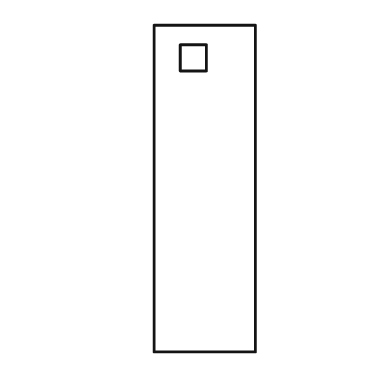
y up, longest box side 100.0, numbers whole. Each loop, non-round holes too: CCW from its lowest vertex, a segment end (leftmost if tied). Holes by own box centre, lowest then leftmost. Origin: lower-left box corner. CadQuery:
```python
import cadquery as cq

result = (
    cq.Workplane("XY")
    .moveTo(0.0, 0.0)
    .lineTo(31.0, 0.0)
    .lineTo(31.0, 100.0)
    .lineTo(0.0, 100.0)
    .close()
    .moveTo(8.0, 86.0)
    .lineTo(16.0, 86.0)
    .lineTo(16.0, 94.0)
    .lineTo(8.0, 94.0)
    .close()
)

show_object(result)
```